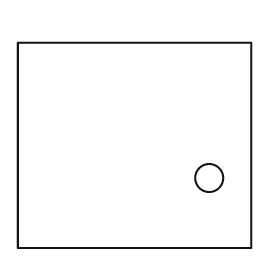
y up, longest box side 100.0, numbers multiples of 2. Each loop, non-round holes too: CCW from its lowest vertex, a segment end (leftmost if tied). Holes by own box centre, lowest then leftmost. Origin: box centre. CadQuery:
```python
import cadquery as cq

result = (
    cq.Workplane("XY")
    .moveTo(-50.0, -44.0)
    .lineTo(50.0, -44.0)
    .lineTo(50.0, 44.0)
    .lineTo(-50.0, 44.0)
    .close()
    .moveTo(32.0, -14.0)
    .circle(6.0)
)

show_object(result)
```